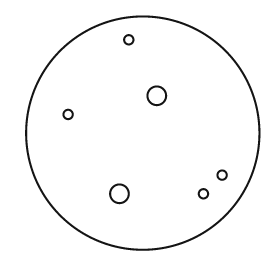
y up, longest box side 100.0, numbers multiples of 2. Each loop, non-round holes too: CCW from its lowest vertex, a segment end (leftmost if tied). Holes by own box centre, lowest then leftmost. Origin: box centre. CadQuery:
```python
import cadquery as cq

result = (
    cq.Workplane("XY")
    .moveTo(0.0, 0.0)
    .circle(50.0)
    .moveTo(-10.0, -26.0)
    .circle(4.0)
    .moveTo(26.0, -26.0)
    .circle(2.0)
    .moveTo(34.0, -18.0)
    .circle(2.0)
    .moveTo(-32.0, 8.0)
    .circle(2.0)
    .moveTo(6.0, 16.0)
    .circle(4.0)
    .moveTo(-6.0, 40.0)
    .circle(2.0)
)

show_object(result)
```